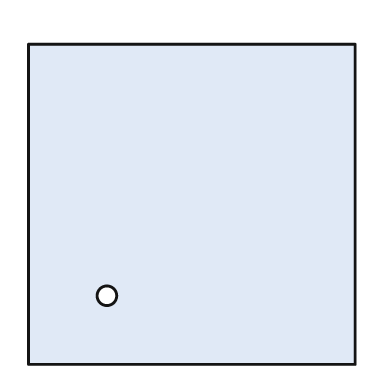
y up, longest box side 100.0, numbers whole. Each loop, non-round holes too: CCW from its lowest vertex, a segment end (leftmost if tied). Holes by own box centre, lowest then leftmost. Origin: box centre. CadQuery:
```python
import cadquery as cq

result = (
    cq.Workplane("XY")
    .moveTo(-50.0, -49.0)
    .lineTo(50.0, -49.0)
    .lineTo(50.0, 49.0)
    .lineTo(-50.0, 49.0)
    .close()
    .moveTo(-26.0, -28.0)
    .circle(3.0)
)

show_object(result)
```